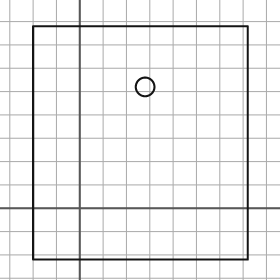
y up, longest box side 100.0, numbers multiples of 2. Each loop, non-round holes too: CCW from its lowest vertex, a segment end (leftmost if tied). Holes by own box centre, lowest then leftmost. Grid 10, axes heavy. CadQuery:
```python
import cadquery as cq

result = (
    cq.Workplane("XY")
    .moveTo(-20.0, -22.0)
    .lineTo(72.0, -22.0)
    .lineTo(72.0, 78.0)
    .lineTo(-20.0, 78.0)
    .close()
    .moveTo(28.0, 52.0)
    .circle(4.0)
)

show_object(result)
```